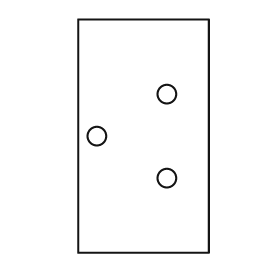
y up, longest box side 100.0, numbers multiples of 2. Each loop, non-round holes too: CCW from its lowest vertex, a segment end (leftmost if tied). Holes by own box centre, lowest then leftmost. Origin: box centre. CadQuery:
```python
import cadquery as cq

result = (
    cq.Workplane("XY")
    .moveTo(-28.0, -50.0)
    .lineTo(28.0, -50.0)
    .lineTo(28.0, 50.0)
    .lineTo(-28.0, 50.0)
    .close()
    .moveTo(10.0, -18.0)
    .circle(4.0)
    .moveTo(-20.0, 0.0)
    .circle(4.0)
    .moveTo(10.0, 18.0)
    .circle(4.0)
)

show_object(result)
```